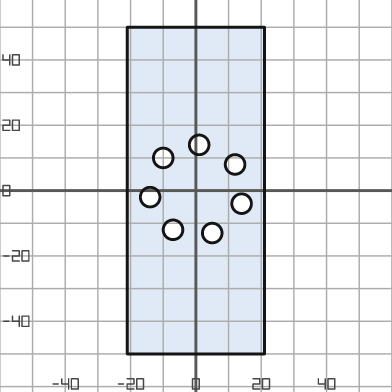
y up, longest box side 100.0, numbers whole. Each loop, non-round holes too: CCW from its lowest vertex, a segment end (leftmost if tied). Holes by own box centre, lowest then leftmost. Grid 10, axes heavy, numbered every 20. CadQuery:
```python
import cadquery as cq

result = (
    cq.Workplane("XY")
    .moveTo(-21.0, -50.0)
    .lineTo(21.0, -50.0)
    .lineTo(21.0, 50.0)
    .lineTo(-21.0, 50.0)
    .close()
    .moveTo(5.0, -13.0)
    .circle(3.0)
    .moveTo(-7.0, -12.0)
    .circle(3.0)
    .moveTo(14.0, -4.0)
    .circle(3.0)
    .moveTo(-14.0, -2.0)
    .circle(3.0)
    .moveTo(12.0, 8.0)
    .circle(3.0)
    .moveTo(-10.0, 10.0)
    .circle(3.0)
    .moveTo(1.0, 14.0)
    .circle(3.0)
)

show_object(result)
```